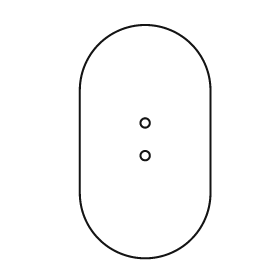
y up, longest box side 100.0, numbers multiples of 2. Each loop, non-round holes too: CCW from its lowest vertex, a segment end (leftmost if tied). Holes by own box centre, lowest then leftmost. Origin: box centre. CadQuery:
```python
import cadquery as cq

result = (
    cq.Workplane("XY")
    .moveTo(-28.0, -22.0)
    .threePointArc((0.0, -50.0), (28.0, -22.0))
    .lineTo(28.0, 22.0)
    .threePointArc((0.0, 50.0), (-28.0, 22.0))
    .close()
    .moveTo(0.0, -6.0)
    .circle(2.0)
    .moveTo(0.0, 8.0)
    .circle(2.0)
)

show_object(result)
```